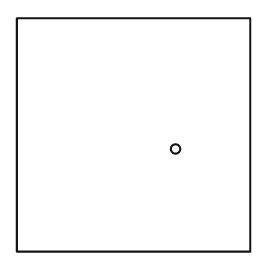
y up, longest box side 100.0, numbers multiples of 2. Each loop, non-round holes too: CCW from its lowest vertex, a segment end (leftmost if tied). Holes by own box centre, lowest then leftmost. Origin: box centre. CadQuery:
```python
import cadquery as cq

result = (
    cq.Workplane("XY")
    .moveTo(-50.0, -50.0)
    .lineTo(50.0, -50.0)
    .lineTo(50.0, 50.0)
    .lineTo(-50.0, 50.0)
    .close()
    .moveTo(18.0, -6.0)
    .circle(2.0)
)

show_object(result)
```